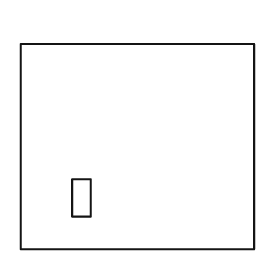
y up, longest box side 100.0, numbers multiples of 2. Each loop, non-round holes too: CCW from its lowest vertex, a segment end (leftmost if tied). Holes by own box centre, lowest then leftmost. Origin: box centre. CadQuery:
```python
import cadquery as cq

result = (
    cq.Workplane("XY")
    .moveTo(-50.0, -44.0)
    .lineTo(50.0, -44.0)
    .lineTo(50.0, 44.0)
    .lineTo(-50.0, 44.0)
    .close()
    .moveTo(-28.0, -30.0)
    .lineTo(-20.0, -30.0)
    .lineTo(-20.0, -14.0)
    .lineTo(-28.0, -14.0)
    .close()
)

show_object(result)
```